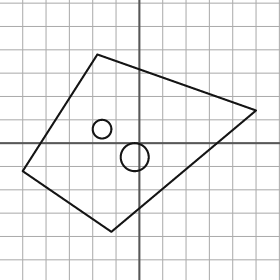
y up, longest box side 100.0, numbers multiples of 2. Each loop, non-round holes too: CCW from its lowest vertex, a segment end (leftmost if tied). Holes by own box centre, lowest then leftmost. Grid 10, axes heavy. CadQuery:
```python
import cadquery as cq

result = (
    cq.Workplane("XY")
    .moveTo(-12.0, -38.0)
    .lineTo(50.0, 14.0)
    .lineTo(-18.0, 38.0)
    .lineTo(-50.0, -12.0)
    .close()
    .moveTo(-2.0, -6.0)
    .circle(6.0)
    .moveTo(-16.0, 6.0)
    .circle(4.0)
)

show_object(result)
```